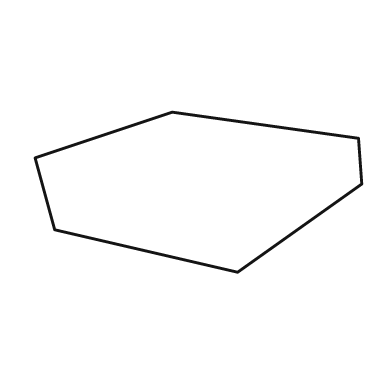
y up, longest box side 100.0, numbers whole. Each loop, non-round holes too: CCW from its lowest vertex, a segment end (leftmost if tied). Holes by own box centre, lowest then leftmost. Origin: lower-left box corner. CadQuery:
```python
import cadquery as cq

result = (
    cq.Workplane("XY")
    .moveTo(62.0, 0.0)
    .lineTo(100.0, 27.0)
    .lineTo(99.0, 41.0)
    .lineTo(42.0, 49.0)
    .lineTo(0.0, 35.0)
    .lineTo(6.0, 13.0)
    .close()
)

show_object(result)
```